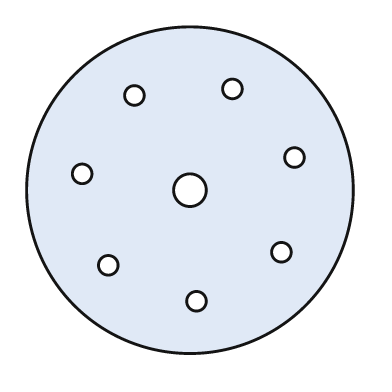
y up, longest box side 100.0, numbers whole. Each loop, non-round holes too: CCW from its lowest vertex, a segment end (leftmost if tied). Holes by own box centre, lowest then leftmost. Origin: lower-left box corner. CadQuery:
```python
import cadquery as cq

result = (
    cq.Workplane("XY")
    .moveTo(50.0, 50.0)
    .circle(50.0)
    .moveTo(52.0, 16.0)
    .circle(3.0)
    .moveTo(25.0, 27.0)
    .circle(3.0)
    .moveTo(78.0, 31.0)
    .circle(3.0)
    .moveTo(50.0, 50.0)
    .circle(5.0)
    .moveTo(17.0, 55.0)
    .circle(3.0)
    .moveTo(82.0, 60.0)
    .circle(3.0)
    .moveTo(33.0, 79.0)
    .circle(3.0)
    .moveTo(63.0, 81.0)
    .circle(3.0)
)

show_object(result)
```